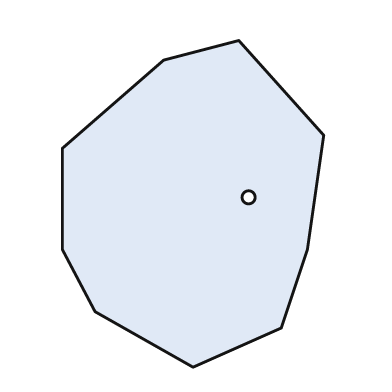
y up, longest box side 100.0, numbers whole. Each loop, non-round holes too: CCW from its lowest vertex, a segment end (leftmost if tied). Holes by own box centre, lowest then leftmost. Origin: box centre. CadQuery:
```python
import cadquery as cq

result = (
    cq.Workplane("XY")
    .moveTo(0.0, -50.0)
    .lineTo(27.0, -38.0)
    .lineTo(35.0, -14.0)
    .lineTo(40.0, 21.0)
    .lineTo(14.0, 50.0)
    .lineTo(-9.0, 44.0)
    .lineTo(-40.0, 17.0)
    .lineTo(-40.0, -14.0)
    .lineTo(-30.0, -33.0)
    .close()
    .moveTo(17.0, 2.0)
    .circle(2.0)
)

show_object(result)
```